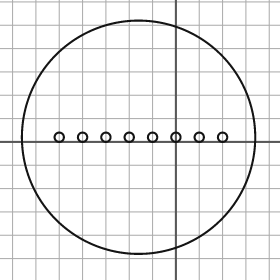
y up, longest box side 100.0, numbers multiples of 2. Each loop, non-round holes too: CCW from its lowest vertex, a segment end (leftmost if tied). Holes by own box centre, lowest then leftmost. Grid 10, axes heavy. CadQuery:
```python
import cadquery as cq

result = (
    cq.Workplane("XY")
    .moveTo(-16.0, 2.0)
    .circle(50.0)
    .moveTo(-50.0, 2.0)
    .circle(2.0)
    .moveTo(-40.0, 2.0)
    .circle(2.0)
    .moveTo(-30.0, 2.0)
    .circle(2.0)
    .moveTo(-20.0, 2.0)
    .circle(2.0)
    .moveTo(-10.0, 2.0)
    .circle(2.0)
    .moveTo(0.0, 2.0)
    .circle(2.0)
    .moveTo(10.0, 2.0)
    .circle(2.0)
    .moveTo(20.0, 2.0)
    .circle(2.0)
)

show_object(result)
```